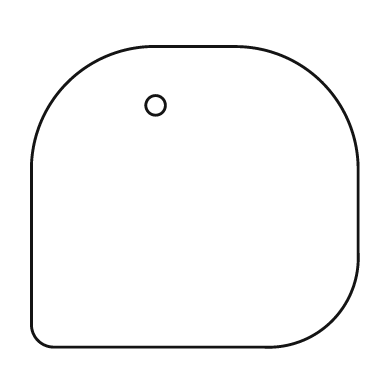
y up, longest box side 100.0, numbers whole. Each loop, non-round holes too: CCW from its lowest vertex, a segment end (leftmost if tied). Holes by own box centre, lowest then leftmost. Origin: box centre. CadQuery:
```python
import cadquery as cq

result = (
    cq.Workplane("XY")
    .moveTo(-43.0, -46.0)
    .lineTo(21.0, -46.0)
    .threePointArc((42.0, -38.0), (50.0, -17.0))
    .lineTo(50.0, 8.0)
    .threePointArc((39.0, 35.0), (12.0, 46.0))
    .lineTo(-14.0, 46.0)
    .threePointArc((-39.0, 35.0), (-50.0, 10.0))
    .lineTo(-50.0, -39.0)
    .threePointArc((-48.0, -44.0), (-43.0, -46.0))
    .close()
    .moveTo(-12.0, 28.0)
    .circle(3.0)
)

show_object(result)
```